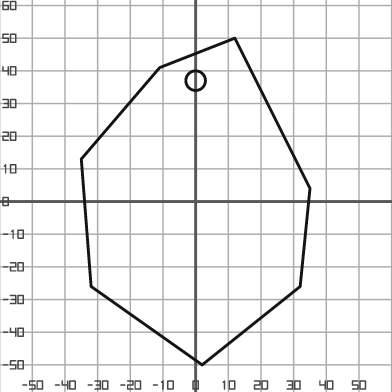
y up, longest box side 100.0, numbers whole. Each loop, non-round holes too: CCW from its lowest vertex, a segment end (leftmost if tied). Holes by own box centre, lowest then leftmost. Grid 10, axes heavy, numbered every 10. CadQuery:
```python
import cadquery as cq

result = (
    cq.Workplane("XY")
    .moveTo(2.0, -50.0)
    .lineTo(32.0, -26.0)
    .lineTo(35.0, 4.0)
    .lineTo(12.0, 50.0)
    .lineTo(-11.0, 41.0)
    .lineTo(-35.0, 13.0)
    .lineTo(-32.0, -26.0)
    .close()
    .moveTo(0.0, 37.0)
    .circle(3.0)
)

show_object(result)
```